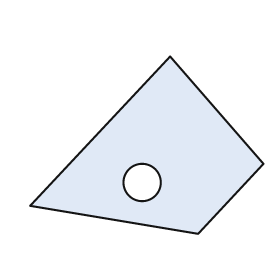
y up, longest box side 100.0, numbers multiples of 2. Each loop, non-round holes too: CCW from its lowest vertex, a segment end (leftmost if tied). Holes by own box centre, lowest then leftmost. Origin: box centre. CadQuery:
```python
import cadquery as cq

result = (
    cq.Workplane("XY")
    .moveTo(22.0, -38.0)
    .lineTo(50.0, -8.0)
    .lineTo(10.0, 38.0)
    .lineTo(-50.0, -26.0)
    .close()
    .moveTo(-2.0, -16.0)
    .circle(8.0)
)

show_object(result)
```